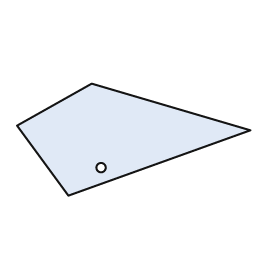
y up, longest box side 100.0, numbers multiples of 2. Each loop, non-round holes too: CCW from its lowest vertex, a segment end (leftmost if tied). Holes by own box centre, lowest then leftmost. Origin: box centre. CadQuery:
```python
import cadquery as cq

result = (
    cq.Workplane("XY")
    .moveTo(-28.0, -24.0)
    .lineTo(50.0, 4.0)
    .lineTo(-18.0, 24.0)
    .lineTo(-50.0, 6.0)
    .close()
    .moveTo(-14.0, -12.0)
    .circle(2.0)
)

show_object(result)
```